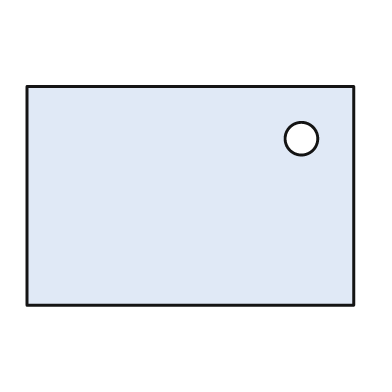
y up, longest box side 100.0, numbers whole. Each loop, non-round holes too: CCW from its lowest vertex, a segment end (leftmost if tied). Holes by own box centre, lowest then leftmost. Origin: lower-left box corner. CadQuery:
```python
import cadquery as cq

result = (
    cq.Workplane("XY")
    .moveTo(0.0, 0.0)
    .lineTo(100.0, 0.0)
    .lineTo(100.0, 67.0)
    .lineTo(0.0, 67.0)
    .close()
    .moveTo(84.0, 51.0)
    .circle(5.0)
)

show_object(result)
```